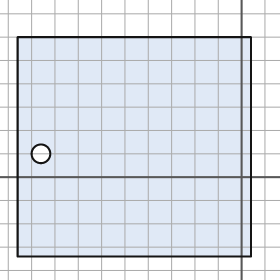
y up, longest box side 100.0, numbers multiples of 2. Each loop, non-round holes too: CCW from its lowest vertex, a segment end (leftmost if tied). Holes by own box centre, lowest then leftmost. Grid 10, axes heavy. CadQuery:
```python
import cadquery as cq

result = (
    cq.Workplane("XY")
    .moveTo(-96.0, -34.0)
    .lineTo(4.0, -34.0)
    .lineTo(4.0, 60.0)
    .lineTo(-96.0, 60.0)
    .close()
    .moveTo(-86.0, 10.0)
    .circle(4.0)
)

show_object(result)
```